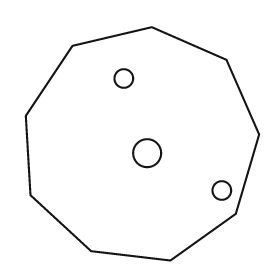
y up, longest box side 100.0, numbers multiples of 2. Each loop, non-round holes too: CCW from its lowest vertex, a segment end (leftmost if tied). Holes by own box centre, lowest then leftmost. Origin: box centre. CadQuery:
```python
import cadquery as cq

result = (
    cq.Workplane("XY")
    .moveTo(12.0, -50.0)
    .lineTo(40.0, -30.0)
    .lineTo(50.0, 4.0)
    .lineTo(36.0, 36.0)
    .lineTo(4.0, 50.0)
    .lineTo(-30.0, 42.0)
    .lineTo(-50.0, 12.0)
    .lineTo(-48.0, -22.0)
    .lineTo(-22.0, -46.0)
    .close()
    .moveTo(34.0, -20.0)
    .circle(4.0)
    .moveTo(2.0, -4.0)
    .circle(6.0)
    .moveTo(-8.0, 28.0)
    .circle(4.0)
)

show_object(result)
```